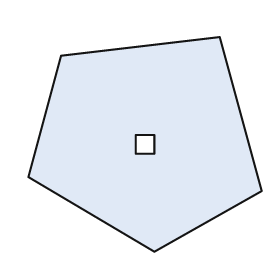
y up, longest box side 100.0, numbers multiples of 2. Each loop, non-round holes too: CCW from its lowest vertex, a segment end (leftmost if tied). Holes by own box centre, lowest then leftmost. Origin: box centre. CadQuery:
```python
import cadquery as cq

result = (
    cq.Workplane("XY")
    .moveTo(4.0, -46.0)
    .lineTo(50.0, -20.0)
    .lineTo(32.0, 46.0)
    .lineTo(-36.0, 38.0)
    .lineTo(-50.0, -14.0)
    .close()
    .moveTo(-4.0, -4.0)
    .lineTo(4.0, -4.0)
    .lineTo(4.0, 4.0)
    .lineTo(-4.0, 4.0)
    .close()
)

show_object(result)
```